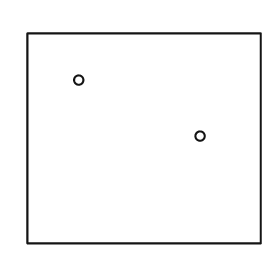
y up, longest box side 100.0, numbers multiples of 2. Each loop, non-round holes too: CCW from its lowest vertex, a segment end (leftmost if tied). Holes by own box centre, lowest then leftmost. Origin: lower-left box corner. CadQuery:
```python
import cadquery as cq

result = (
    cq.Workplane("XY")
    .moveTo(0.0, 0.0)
    .lineTo(100.0, 0.0)
    .lineTo(100.0, 90.0)
    .lineTo(0.0, 90.0)
    .close()
    .moveTo(74.0, 46.0)
    .circle(2.0)
    .moveTo(22.0, 70.0)
    .circle(2.0)
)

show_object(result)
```